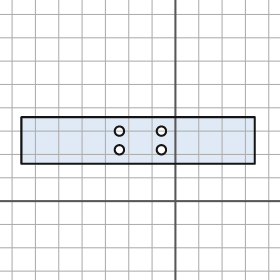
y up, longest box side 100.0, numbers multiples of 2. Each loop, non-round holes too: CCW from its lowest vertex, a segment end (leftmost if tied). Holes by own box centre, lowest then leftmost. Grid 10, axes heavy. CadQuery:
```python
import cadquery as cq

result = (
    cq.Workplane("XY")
    .moveTo(-66.0, 16.0)
    .lineTo(34.0, 16.0)
    .lineTo(34.0, 36.0)
    .lineTo(-66.0, 36.0)
    .close()
    .moveTo(-24.0, 22.0)
    .circle(2.0)
    .moveTo(-6.0, 22.0)
    .circle(2.0)
    .moveTo(-24.0, 30.0)
    .circle(2.0)
    .moveTo(-6.0, 30.0)
    .circle(2.0)
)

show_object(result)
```